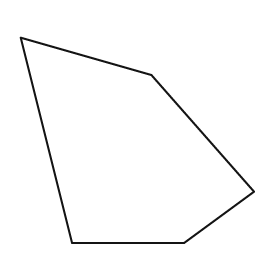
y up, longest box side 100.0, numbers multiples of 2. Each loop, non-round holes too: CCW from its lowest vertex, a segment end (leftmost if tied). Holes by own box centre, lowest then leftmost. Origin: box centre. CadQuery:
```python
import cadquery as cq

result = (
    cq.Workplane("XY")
    .moveTo(-28.0, -44.0)
    .lineTo(20.0, -44.0)
    .lineTo(50.0, -22.0)
    .lineTo(6.0, 28.0)
    .lineTo(-50.0, 44.0)
    .close()
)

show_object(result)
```